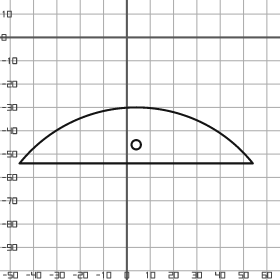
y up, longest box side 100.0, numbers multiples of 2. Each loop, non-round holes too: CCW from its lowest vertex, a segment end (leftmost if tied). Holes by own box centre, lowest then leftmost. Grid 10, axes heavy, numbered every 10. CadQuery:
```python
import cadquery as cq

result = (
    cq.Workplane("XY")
    .moveTo(-46.0, -54.0)
    .lineTo(54.0, -54.0)
    .threePointArc((4.0, -30.0), (-46.0, -54.0))
    .close()
    .moveTo(4.0, -46.0)
    .circle(2.0)
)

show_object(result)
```